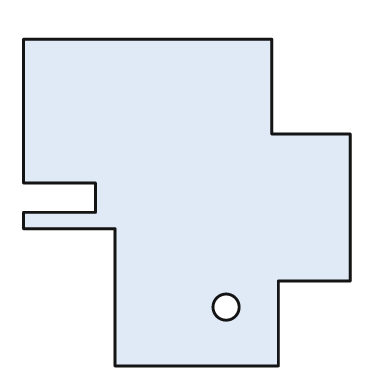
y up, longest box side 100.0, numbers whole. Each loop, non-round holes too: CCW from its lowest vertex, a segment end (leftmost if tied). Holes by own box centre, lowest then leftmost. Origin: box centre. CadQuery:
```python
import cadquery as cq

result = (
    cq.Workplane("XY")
    .moveTo(-22.0, -50.0)
    .lineTo(28.0, -50.0)
    .lineTo(28.0, -24.0)
    .lineTo(50.0, -24.0)
    .lineTo(50.0, 21.0)
    .lineTo(26.0, 21.0)
    .lineTo(26.0, 50.0)
    .lineTo(-50.0, 50.0)
    .lineTo(-50.0, 6.0)
    .lineTo(-28.0, 6.0)
    .lineTo(-28.0, -3.0)
    .lineTo(-50.0, -3.0)
    .lineTo(-50.0, -8.0)
    .lineTo(-22.0, -8.0)
    .close()
    .moveTo(12.0, -32.0)
    .circle(4.0)
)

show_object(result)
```